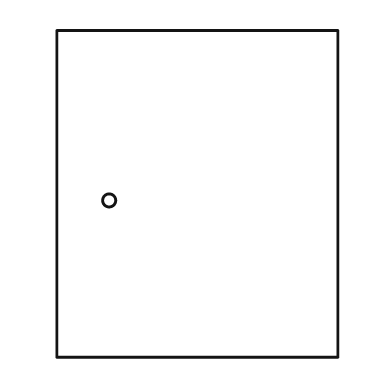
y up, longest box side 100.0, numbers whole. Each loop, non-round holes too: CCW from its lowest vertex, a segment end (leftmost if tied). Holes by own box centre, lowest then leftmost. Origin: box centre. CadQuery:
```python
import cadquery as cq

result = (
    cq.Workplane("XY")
    .moveTo(-43.0, -50.0)
    .lineTo(43.0, -50.0)
    .lineTo(43.0, 50.0)
    .lineTo(-43.0, 50.0)
    .close()
    .moveTo(-27.0, -2.0)
    .circle(2.0)
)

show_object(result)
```